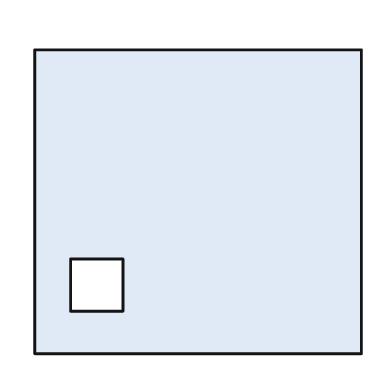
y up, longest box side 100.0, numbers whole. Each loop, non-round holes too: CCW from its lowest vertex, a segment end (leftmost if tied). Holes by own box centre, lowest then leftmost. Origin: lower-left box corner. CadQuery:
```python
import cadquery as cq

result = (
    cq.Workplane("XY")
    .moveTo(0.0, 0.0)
    .lineTo(100.0, 0.0)
    .lineTo(100.0, 93.0)
    .lineTo(0.0, 93.0)
    .close()
    .moveTo(11.0, 13.0)
    .lineTo(27.0, 13.0)
    .lineTo(27.0, 29.0)
    .lineTo(11.0, 29.0)
    .close()
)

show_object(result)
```